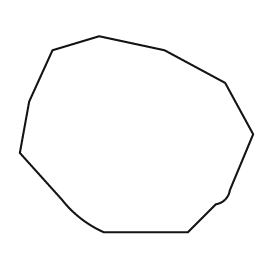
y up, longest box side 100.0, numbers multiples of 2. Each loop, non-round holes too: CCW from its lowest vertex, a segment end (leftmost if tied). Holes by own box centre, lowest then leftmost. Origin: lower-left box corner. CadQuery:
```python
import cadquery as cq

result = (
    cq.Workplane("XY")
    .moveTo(36.0, 0.0)
    .lineTo(72.0, 0.0)
    .lineTo(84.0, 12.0)
    .threePointArc((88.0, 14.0), (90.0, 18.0))
    .lineTo(100.0, 42.0)
    .lineTo(88.0, 64.0)
    .lineTo(62.0, 78.0)
    .lineTo(34.0, 84.0)
    .lineTo(14.0, 78.0)
    .lineTo(4.0, 56.0)
    .lineTo(0.0, 34.0)
    .lineTo(18.0, 14.0)
    .threePointArc((26.0, 6.0), (36.0, 0.0))
    .close()
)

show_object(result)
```